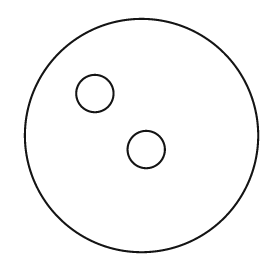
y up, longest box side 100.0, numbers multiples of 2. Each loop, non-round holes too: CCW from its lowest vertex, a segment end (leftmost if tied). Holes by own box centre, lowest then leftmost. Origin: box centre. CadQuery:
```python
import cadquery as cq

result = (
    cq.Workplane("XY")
    .moveTo(0.0, 0.0)
    .circle(50.0)
    .moveTo(2.0, -6.0)
    .circle(8.0)
    .moveTo(-20.0, 18.0)
    .circle(8.0)
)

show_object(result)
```